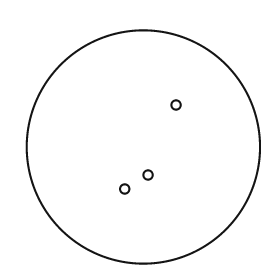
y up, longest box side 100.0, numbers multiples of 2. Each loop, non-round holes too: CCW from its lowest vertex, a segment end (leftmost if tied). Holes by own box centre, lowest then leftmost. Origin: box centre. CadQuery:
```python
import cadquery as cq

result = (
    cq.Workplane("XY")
    .moveTo(0.0, 0.0)
    .circle(50.0)
    .moveTo(-8.0, -18.0)
    .circle(2.0)
    .moveTo(2.0, -12.0)
    .circle(2.0)
    .moveTo(14.0, 18.0)
    .circle(2.0)
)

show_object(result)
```